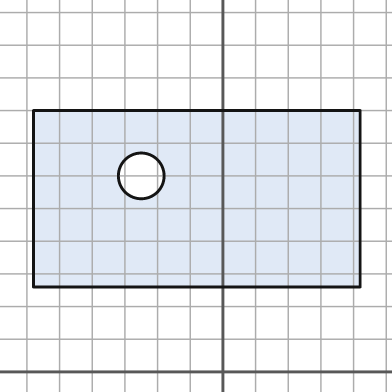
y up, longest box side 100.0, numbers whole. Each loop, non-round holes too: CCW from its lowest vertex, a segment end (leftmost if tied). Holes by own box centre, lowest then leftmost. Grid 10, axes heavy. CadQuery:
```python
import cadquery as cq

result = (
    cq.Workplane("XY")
    .moveTo(-58.0, 26.0)
    .lineTo(42.0, 26.0)
    .lineTo(42.0, 80.0)
    .lineTo(-58.0, 80.0)
    .close()
    .moveTo(-25.0, 60.0)
    .circle(7.0)
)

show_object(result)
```